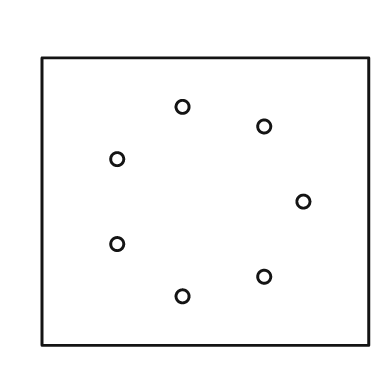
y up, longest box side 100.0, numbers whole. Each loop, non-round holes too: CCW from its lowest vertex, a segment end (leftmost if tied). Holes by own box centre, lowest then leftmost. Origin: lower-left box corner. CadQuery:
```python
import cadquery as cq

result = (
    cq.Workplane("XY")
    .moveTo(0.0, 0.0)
    .lineTo(100.0, 0.0)
    .lineTo(100.0, 88.0)
    .lineTo(0.0, 88.0)
    .close()
    .moveTo(43.0, 15.0)
    .circle(2.0)
    .moveTo(68.0, 21.0)
    .circle(2.0)
    .moveTo(23.0, 31.0)
    .circle(2.0)
    .moveTo(80.0, 44.0)
    .circle(2.0)
    .moveTo(23.0, 57.0)
    .circle(2.0)
    .moveTo(68.0, 67.0)
    .circle(2.0)
    .moveTo(43.0, 73.0)
    .circle(2.0)
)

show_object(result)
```